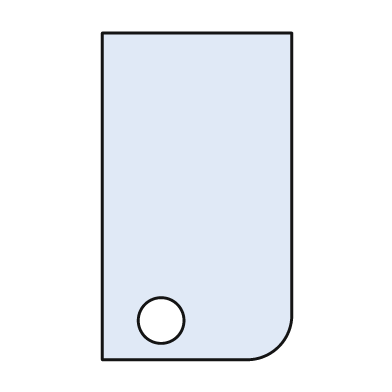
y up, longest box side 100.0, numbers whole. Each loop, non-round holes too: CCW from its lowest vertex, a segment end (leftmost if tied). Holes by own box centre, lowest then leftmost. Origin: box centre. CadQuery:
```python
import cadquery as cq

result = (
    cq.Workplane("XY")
    .moveTo(-29.0, -50.0)
    .lineTo(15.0, -50.0)
    .threePointArc((25.0, -46.0), (29.0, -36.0))
    .lineTo(29.0, 50.0)
    .lineTo(-29.0, 50.0)
    .close()
    .moveTo(-11.0, -38.0)
    .circle(7.0)
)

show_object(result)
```